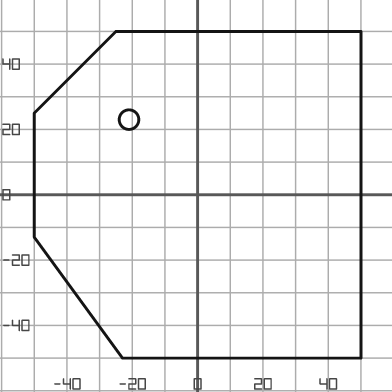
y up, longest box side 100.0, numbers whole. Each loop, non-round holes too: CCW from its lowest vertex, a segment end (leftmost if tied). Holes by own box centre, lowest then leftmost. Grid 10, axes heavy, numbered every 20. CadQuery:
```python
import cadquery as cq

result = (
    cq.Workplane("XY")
    .moveTo(-23.0, -50.0)
    .lineTo(50.0, -50.0)
    .lineTo(50.0, 50.0)
    .lineTo(-25.0, 50.0)
    .lineTo(-50.0, 25.0)
    .lineTo(-50.0, -13.0)
    .close()
    .moveTo(-21.0, 23.0)
    .circle(3.0)
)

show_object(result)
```